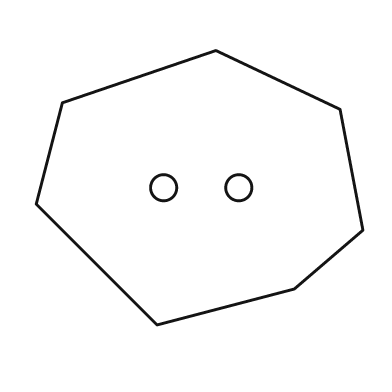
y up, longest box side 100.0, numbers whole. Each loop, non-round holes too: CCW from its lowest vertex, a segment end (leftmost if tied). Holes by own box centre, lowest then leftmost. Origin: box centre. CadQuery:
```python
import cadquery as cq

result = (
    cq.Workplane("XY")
    .moveTo(-13.0, -42.0)
    .lineTo(29.0, -31.0)
    .lineTo(50.0, -13.0)
    .lineTo(43.0, 24.0)
    .lineTo(5.0, 42.0)
    .lineTo(-42.0, 26.0)
    .lineTo(-50.0, -5.0)
    .close()
    .moveTo(-11.0, 0.0)
    .circle(4.0)
    .moveTo(12.0, 0.0)
    .circle(4.0)
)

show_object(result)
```